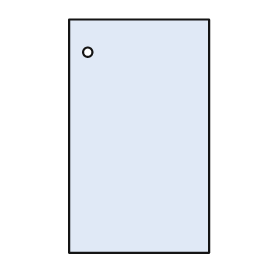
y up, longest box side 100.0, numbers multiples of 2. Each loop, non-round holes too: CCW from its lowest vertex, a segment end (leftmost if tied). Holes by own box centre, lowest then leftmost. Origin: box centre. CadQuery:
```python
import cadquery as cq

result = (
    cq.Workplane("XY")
    .moveTo(-30.0, -50.0)
    .lineTo(30.0, -50.0)
    .lineTo(30.0, 50.0)
    .lineTo(-30.0, 50.0)
    .close()
    .moveTo(-22.0, 36.0)
    .circle(2.0)
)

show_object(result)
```